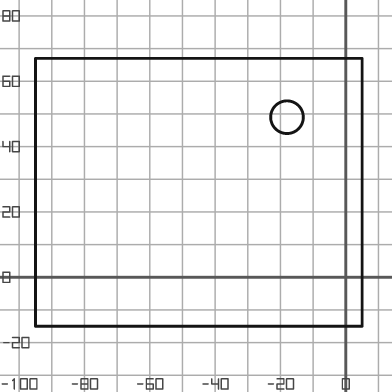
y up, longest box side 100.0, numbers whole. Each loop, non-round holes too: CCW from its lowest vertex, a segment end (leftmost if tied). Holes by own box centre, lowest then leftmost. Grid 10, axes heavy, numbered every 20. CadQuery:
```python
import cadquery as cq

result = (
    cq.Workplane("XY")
    .moveTo(-95.0, -15.0)
    .lineTo(5.0, -15.0)
    .lineTo(5.0, 67.0)
    .lineTo(-95.0, 67.0)
    .close()
    .moveTo(-18.0, 49.0)
    .circle(5.0)
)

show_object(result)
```